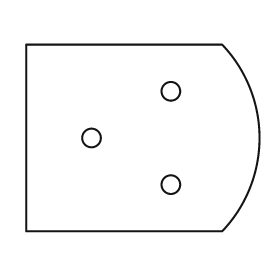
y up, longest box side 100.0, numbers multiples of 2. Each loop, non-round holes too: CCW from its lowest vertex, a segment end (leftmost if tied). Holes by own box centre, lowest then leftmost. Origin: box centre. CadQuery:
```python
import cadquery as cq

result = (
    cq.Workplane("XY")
    .moveTo(-50.0, -40.0)
    .lineTo(34.0, -40.0)
    .threePointArc((50.0, 0.0), (34.0, 40.0))
    .lineTo(-50.0, 40.0)
    .close()
    .moveTo(12.0, -20.0)
    .circle(4.0)
    .moveTo(-22.0, 0.0)
    .circle(4.0)
    .moveTo(12.0, 20.0)
    .circle(4.0)
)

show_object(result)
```